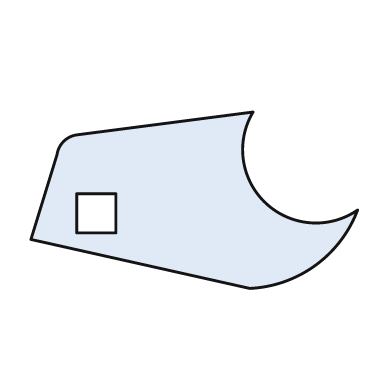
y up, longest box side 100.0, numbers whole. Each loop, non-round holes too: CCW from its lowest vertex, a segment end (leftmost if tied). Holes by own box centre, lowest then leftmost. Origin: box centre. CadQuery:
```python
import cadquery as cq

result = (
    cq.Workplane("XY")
    .moveTo(17.0, -27.0)
    .threePointArc((37.0, -20.0), (50.0, -3.0))
    .threePointArc((22.0, -1.0), (18.0, 27.0))
    .lineTo(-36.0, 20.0)
    .threePointArc((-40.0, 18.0), (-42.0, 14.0))
    .lineTo(-50.0, -12.0)
    .close()
    .moveTo(-36.0, -10.0)
    .lineTo(-24.0, -10.0)
    .lineTo(-24.0, 2.0)
    .lineTo(-36.0, 2.0)
    .close()
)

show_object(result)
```